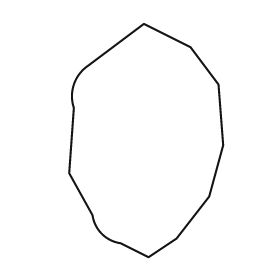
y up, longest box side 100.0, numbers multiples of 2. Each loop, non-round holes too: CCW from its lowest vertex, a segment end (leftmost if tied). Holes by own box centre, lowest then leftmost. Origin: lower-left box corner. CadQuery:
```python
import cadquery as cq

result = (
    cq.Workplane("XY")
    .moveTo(34.0, 0.0)
    .lineTo(46.0, 8.0)
    .lineTo(60.0, 26.0)
    .lineTo(66.0, 48.0)
    .lineTo(64.0, 74.0)
    .lineTo(52.0, 90.0)
    .lineTo(32.0, 100.0)
    .lineTo(8.0, 82.0)
    .threePointArc((2.0, 74.0), (2.0, 64.0))
    .lineTo(0.0, 36.0)
    .lineTo(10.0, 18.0)
    .threePointArc((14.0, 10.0), (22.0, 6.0))
    .close()
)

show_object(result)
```